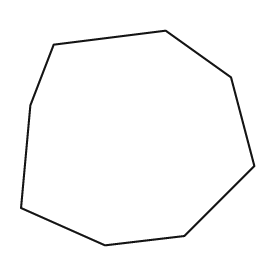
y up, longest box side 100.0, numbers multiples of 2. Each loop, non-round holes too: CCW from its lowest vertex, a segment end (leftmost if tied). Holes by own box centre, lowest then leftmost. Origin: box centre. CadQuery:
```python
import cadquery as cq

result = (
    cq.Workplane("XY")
    .moveTo(-14.0, -46.0)
    .lineTo(20.0, -42.0)
    .lineTo(50.0, -12.0)
    .lineTo(40.0, 26.0)
    .lineTo(12.0, 46.0)
    .lineTo(-36.0, 40.0)
    .lineTo(-46.0, 14.0)
    .lineTo(-50.0, -30.0)
    .close()
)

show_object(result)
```